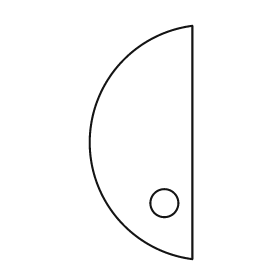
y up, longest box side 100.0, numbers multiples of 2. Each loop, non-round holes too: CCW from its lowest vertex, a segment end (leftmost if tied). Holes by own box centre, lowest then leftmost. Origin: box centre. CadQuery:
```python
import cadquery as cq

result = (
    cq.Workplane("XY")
    .moveTo(22.0, -50.0)
    .lineTo(22.0, 50.0)
    .threePointArc((-22.0, 0.0), (22.0, -50.0))
    .close()
    .moveTo(10.0, -26.0)
    .circle(6.0)
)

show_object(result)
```